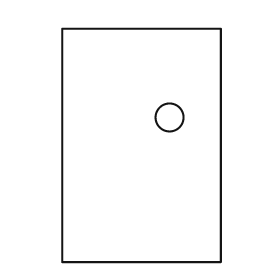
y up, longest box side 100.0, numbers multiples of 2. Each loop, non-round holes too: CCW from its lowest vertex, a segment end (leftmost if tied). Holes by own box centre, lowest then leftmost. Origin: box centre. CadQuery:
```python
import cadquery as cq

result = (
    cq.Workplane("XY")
    .moveTo(-34.0, -50.0)
    .lineTo(34.0, -50.0)
    .lineTo(34.0, 50.0)
    .lineTo(-34.0, 50.0)
    .close()
    .moveTo(12.0, 12.0)
    .circle(6.0)
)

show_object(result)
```